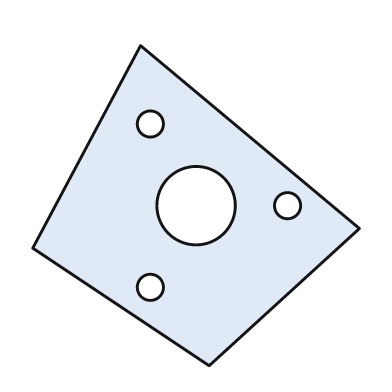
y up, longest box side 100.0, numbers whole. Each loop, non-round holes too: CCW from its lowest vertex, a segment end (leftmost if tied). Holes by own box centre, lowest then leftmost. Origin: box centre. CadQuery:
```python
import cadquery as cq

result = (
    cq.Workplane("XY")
    .moveTo(4.0, -49.0)
    .lineTo(50.0, -7.0)
    .lineTo(-17.0, 49.0)
    .lineTo(-50.0, -13.0)
    .close()
    .moveTo(-14.0, -25.0)
    .circle(4.0)
    .moveTo(0.0, 0.0)
    .circle(12.0)
    .moveTo(28.0, 0.0)
    .circle(4.0)
    .moveTo(-14.0, 25.0)
    .circle(4.0)
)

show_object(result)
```